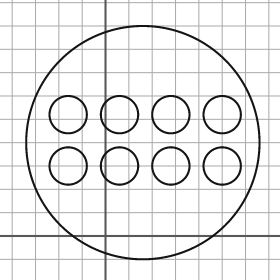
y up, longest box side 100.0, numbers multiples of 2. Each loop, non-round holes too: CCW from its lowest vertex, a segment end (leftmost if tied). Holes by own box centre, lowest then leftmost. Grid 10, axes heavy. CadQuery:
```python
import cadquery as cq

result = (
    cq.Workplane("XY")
    .moveTo(16.0, 40.0)
    .circle(50.0)
    .moveTo(-16.0, 30.0)
    .circle(8.0)
    .moveTo(6.0, 30.0)
    .circle(8.0)
    .moveTo(28.0, 30.0)
    .circle(8.0)
    .moveTo(50.0, 30.0)
    .circle(8.0)
    .moveTo(-16.0, 52.0)
    .circle(8.0)
    .moveTo(6.0, 52.0)
    .circle(8.0)
    .moveTo(28.0, 52.0)
    .circle(8.0)
    .moveTo(50.0, 52.0)
    .circle(8.0)
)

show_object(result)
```